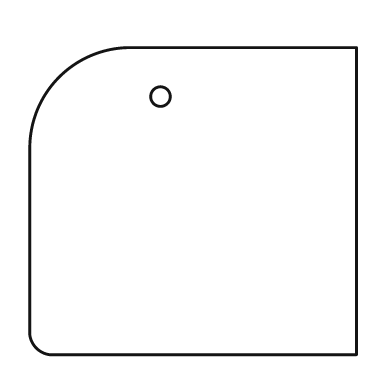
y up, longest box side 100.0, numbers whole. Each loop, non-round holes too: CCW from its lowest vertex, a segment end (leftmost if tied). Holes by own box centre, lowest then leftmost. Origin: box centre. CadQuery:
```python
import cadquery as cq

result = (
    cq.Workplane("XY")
    .moveTo(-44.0, -47.0)
    .lineTo(50.0, -47.0)
    .lineTo(50.0, 47.0)
    .lineTo(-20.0, 47.0)
    .threePointArc((-41.0, 38.0), (-50.0, 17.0))
    .lineTo(-50.0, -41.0)
    .threePointArc((-48.0, -45.0), (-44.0, -47.0))
    .close()
    .moveTo(-10.0, 32.0)
    .circle(3.0)
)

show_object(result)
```